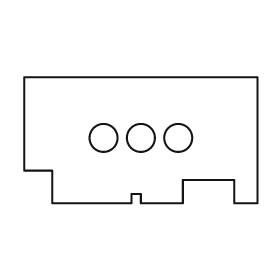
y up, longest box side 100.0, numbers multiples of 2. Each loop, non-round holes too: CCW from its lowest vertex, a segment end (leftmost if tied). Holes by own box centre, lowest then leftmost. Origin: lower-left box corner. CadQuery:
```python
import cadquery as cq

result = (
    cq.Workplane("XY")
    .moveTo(12.0, 0.0)
    .lineTo(46.0, 0.0)
    .lineTo(46.0, 4.0)
    .lineTo(50.0, 4.0)
    .lineTo(50.0, 0.0)
    .lineTo(68.0, 0.0)
    .lineTo(68.0, 10.0)
    .lineTo(90.0, 10.0)
    .lineTo(90.0, 0.0)
    .lineTo(100.0, 0.0)
    .lineTo(100.0, 54.0)
    .lineTo(0.0, 54.0)
    .lineTo(0.0, 14.0)
    .lineTo(12.0, 14.0)
    .close()
    .moveTo(34.0, 28.0)
    .circle(6.0)
    .moveTo(50.0, 28.0)
    .circle(6.0)
    .moveTo(66.0, 28.0)
    .circle(6.0)
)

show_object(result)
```